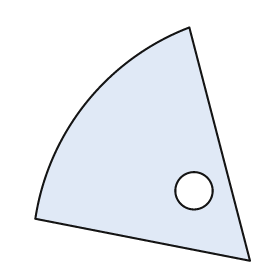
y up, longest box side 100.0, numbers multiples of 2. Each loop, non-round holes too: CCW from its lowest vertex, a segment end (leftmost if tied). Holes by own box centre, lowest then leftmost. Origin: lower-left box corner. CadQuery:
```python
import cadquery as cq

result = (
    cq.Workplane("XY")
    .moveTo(92.0, 0.0)
    .lineTo(66.0, 100.0)
    .threePointArc((22.0, 68.0), (0.0, 18.0))
    .close()
    .moveTo(68.0, 30.0)
    .circle(8.0)
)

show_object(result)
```